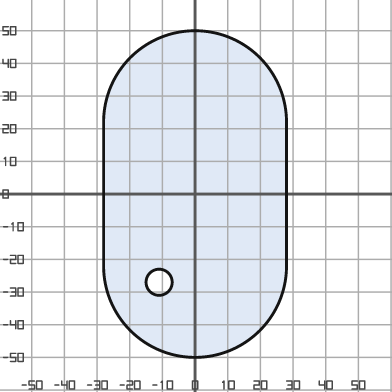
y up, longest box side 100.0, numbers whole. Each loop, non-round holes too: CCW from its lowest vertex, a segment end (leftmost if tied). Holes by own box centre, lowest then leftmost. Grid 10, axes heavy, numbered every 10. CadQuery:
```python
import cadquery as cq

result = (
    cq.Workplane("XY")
    .moveTo(-28.0, -22.0)
    .threePointArc((0.0, -50.0), (28.0, -22.0))
    .lineTo(28.0, 22.0)
    .threePointArc((0.0, 50.0), (-28.0, 22.0))
    .close()
    .moveTo(-11.0, -27.0)
    .circle(4.0)
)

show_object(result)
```